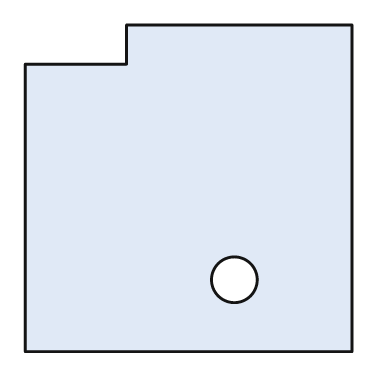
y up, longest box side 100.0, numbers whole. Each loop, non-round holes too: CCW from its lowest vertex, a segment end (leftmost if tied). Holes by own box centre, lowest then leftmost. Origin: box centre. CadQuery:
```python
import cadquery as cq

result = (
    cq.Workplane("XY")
    .moveTo(-50.0, -50.0)
    .lineTo(50.0, -50.0)
    .lineTo(50.0, 50.0)
    .lineTo(-19.0, 50.0)
    .lineTo(-19.0, 38.0)
    .lineTo(-50.0, 38.0)
    .close()
    .moveTo(14.0, -28.0)
    .circle(7.0)
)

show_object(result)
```